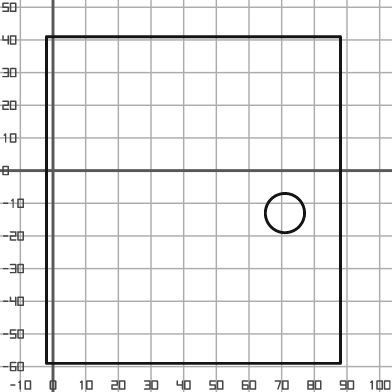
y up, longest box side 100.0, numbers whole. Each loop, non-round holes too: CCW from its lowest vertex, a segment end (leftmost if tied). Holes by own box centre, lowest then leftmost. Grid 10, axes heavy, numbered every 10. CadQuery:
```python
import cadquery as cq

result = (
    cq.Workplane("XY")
    .moveTo(-2.0, -59.0)
    .lineTo(88.0, -59.0)
    .lineTo(88.0, 41.0)
    .lineTo(-2.0, 41.0)
    .close()
    .moveTo(71.0, -13.0)
    .circle(6.0)
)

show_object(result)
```